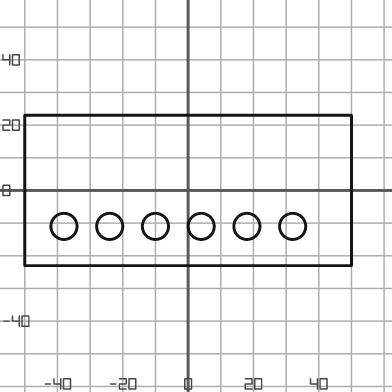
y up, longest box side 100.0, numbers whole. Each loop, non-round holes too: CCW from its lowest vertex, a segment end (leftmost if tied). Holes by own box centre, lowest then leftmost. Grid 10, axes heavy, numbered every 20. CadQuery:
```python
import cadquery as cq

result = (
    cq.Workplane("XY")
    .moveTo(-50.0, -23.0)
    .lineTo(50.0, -23.0)
    .lineTo(50.0, 23.0)
    .lineTo(-50.0, 23.0)
    .close()
    .moveTo(-38.0, -11.0)
    .circle(4.0)
    .moveTo(-24.0, -11.0)
    .circle(4.0)
    .moveTo(-10.0, -11.0)
    .circle(4.0)
    .moveTo(4.0, -11.0)
    .circle(4.0)
    .moveTo(18.0, -11.0)
    .circle(4.0)
    .moveTo(32.0, -11.0)
    .circle(4.0)
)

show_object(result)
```